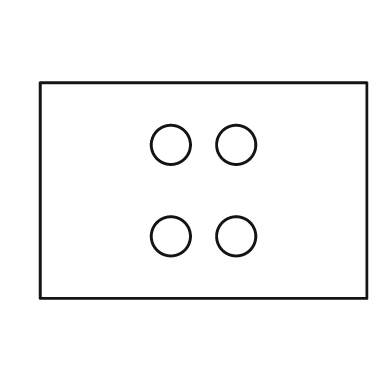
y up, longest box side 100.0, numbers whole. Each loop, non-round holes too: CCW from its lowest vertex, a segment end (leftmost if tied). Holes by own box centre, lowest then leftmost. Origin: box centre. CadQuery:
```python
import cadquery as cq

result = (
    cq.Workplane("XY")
    .moveTo(-50.0, -33.0)
    .lineTo(50.0, -33.0)
    .lineTo(50.0, 33.0)
    .lineTo(-50.0, 33.0)
    .close()
    .moveTo(-10.0, -14.0)
    .circle(6.0)
    .moveTo(10.0, -14.0)
    .circle(6.0)
    .moveTo(-10.0, 14.0)
    .circle(6.0)
    .moveTo(10.0, 14.0)
    .circle(6.0)
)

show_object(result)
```